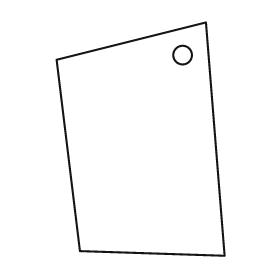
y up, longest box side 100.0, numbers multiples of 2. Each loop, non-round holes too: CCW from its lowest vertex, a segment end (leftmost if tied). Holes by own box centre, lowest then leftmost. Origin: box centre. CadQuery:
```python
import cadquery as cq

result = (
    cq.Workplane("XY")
    .moveTo(36.0, -50.0)
    .lineTo(28.0, 50.0)
    .lineTo(-36.0, 34.0)
    .lineTo(-26.0, -48.0)
    .close()
    .moveTo(18.0, 36.0)
    .circle(4.0)
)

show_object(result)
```